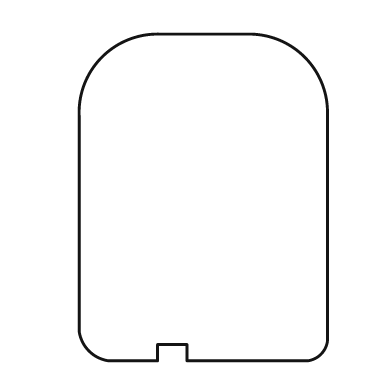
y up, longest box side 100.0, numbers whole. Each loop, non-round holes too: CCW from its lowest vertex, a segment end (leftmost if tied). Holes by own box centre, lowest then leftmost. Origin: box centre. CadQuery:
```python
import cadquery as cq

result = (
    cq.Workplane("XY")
    .moveTo(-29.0, -50.0)
    .lineTo(-14.0, -50.0)
    .lineTo(-14.0, -45.0)
    .lineTo(-5.0, -45.0)
    .lineTo(-5.0, -50.0)
    .lineTo(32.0, -50.0)
    .threePointArc((36.0, -48.0), (38.0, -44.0))
    .lineTo(38.0, 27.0)
    .threePointArc((31.0, 43.0), (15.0, 50.0))
    .lineTo(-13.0, 50.0)
    .threePointArc((-31.0, 43.0), (-38.0, 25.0))
    .lineTo(-38.0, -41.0)
    .threePointArc((-35.0, -47.0), (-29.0, -50.0))
    .close()
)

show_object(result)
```